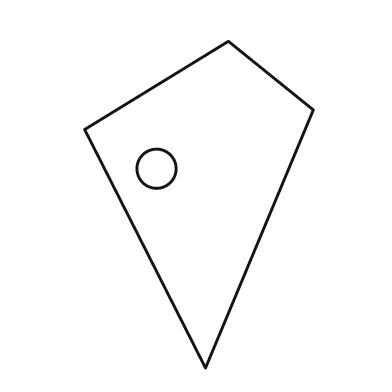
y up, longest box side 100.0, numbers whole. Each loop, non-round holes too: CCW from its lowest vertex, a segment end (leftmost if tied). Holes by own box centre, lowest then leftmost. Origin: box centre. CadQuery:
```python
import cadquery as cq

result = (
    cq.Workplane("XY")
    .moveTo(2.0, -50.0)
    .lineTo(35.0, 29.0)
    .lineTo(9.0, 50.0)
    .lineTo(-35.0, 23.0)
    .close()
    .moveTo(-13.0, 11.0)
    .circle(6.0)
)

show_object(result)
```